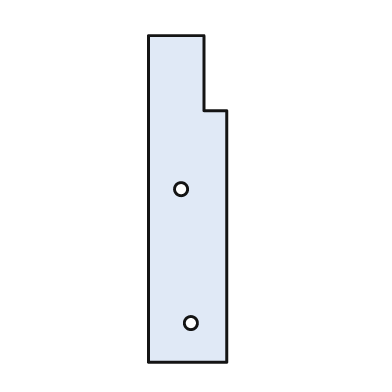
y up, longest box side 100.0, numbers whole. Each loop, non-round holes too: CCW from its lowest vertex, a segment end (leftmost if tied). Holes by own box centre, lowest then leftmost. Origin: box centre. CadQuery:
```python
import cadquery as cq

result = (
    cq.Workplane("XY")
    .moveTo(-12.0, -50.0)
    .lineTo(12.0, -50.0)
    .lineTo(12.0, 27.0)
    .lineTo(5.0, 27.0)
    .lineTo(5.0, 50.0)
    .lineTo(-12.0, 50.0)
    .close()
    .moveTo(1.0, -38.0)
    .circle(2.0)
    .moveTo(-2.0, 3.0)
    .circle(2.0)
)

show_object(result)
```